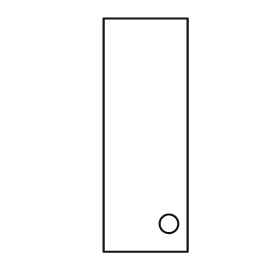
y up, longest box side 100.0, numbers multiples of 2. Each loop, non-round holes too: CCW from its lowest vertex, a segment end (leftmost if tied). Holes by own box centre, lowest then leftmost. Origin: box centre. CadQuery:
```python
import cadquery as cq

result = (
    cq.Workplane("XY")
    .moveTo(-18.0, -50.0)
    .lineTo(18.0, -50.0)
    .lineTo(18.0, 50.0)
    .lineTo(-18.0, 50.0)
    .close()
    .moveTo(10.0, -38.0)
    .circle(4.0)
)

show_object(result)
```